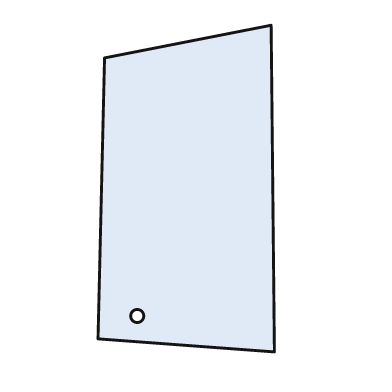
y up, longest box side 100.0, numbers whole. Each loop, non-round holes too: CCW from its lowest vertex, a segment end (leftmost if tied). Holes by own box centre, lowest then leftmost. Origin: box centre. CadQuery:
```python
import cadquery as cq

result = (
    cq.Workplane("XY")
    .moveTo(27.0, -50.0)
    .lineTo(26.0, 50.0)
    .lineTo(-25.0, 40.0)
    .lineTo(-27.0, -46.0)
    .close()
    .moveTo(-15.0, -39.0)
    .circle(2.0)
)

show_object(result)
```